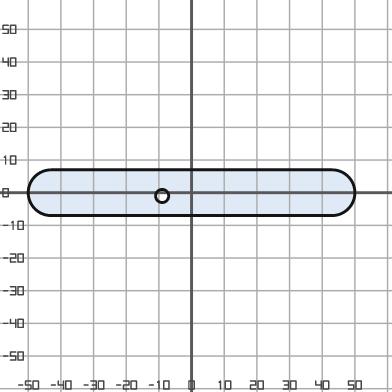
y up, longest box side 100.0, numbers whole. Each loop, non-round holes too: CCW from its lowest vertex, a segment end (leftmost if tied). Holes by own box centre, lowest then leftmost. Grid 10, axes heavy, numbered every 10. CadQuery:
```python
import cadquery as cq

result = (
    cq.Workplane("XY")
    .moveTo(-43.0, -7.0)
    .lineTo(43.0, -7.0)
    .threePointArc((50.0, 0.0), (43.0, 7.0))
    .lineTo(-43.0, 7.0)
    .threePointArc((-50.0, 0.0), (-43.0, -7.0))
    .close()
    .moveTo(-9.0, -1.0)
    .circle(2.0)
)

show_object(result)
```